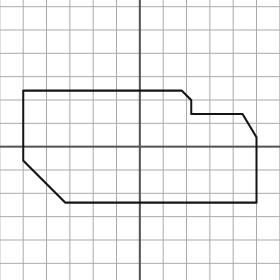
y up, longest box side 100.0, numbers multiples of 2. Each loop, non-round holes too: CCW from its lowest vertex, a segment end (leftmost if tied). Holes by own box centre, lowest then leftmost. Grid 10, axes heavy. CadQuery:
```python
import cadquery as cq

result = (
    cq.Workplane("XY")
    .moveTo(-32.0, -24.0)
    .lineTo(50.0, -24.0)
    .lineTo(50.0, 4.0)
    .lineTo(44.0, 14.0)
    .lineTo(22.0, 14.0)
    .lineTo(22.0, 20.0)
    .lineTo(18.0, 24.0)
    .lineTo(-50.0, 24.0)
    .lineTo(-50.0, -6.0)
    .close()
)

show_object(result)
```